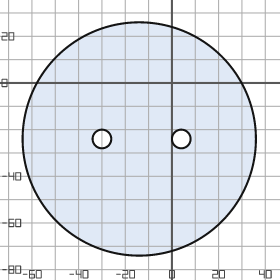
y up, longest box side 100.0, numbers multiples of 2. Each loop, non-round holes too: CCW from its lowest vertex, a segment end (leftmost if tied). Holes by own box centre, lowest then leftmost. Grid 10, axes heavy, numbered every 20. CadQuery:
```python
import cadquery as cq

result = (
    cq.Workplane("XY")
    .moveTo(-14.0, -24.0)
    .circle(50.0)
    .moveTo(-30.0, -24.0)
    .circle(4.0)
    .moveTo(4.0, -24.0)
    .circle(4.0)
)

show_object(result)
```